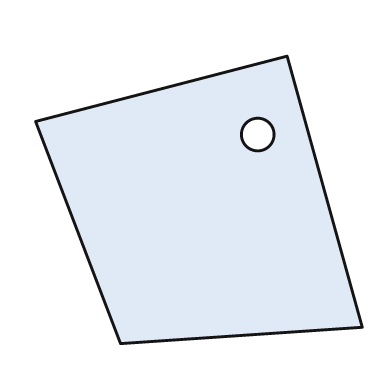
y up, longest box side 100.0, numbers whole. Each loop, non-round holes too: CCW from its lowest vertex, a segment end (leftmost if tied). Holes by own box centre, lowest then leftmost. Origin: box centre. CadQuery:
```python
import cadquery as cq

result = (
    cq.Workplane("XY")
    .moveTo(-24.0, -44.0)
    .lineTo(50.0, -39.0)
    .lineTo(27.0, 44.0)
    .lineTo(-50.0, 24.0)
    .close()
    .moveTo(18.0, 20.0)
    .circle(5.0)
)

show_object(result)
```